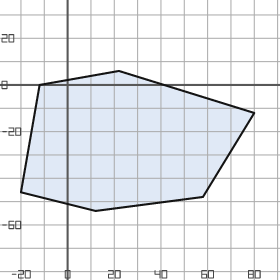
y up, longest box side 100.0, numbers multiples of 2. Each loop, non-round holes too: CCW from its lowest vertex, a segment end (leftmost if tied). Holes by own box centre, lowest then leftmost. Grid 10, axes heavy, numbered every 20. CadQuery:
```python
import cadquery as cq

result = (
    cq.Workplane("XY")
    .moveTo(12.0, -54.0)
    .lineTo(58.0, -48.0)
    .lineTo(80.0, -12.0)
    .lineTo(22.0, 6.0)
    .lineTo(-12.0, 0.0)
    .lineTo(-20.0, -46.0)
    .close()
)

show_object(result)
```